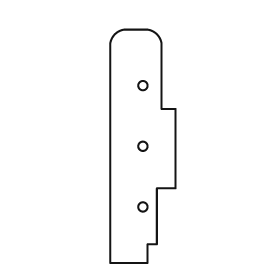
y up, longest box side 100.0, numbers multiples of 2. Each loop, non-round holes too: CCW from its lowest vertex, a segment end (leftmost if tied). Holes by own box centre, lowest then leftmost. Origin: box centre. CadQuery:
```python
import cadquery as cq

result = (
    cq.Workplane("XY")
    .moveTo(-14.0, -50.0)
    .lineTo(2.0, -50.0)
    .lineTo(2.0, -42.0)
    .lineTo(6.0, -42.0)
    .lineTo(6.0, -18.0)
    .lineTo(14.0, -18.0)
    .lineTo(14.0, 16.0)
    .lineTo(8.0, 16.0)
    .lineTo(8.0, 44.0)
    .threePointArc((6.0, 48.0), (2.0, 50.0))
    .lineTo(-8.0, 50.0)
    .threePointArc((-12.0, 48.0), (-14.0, 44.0))
    .close()
    .moveTo(0.0, -26.0)
    .circle(2.0)
    .moveTo(0.0, 0.0)
    .circle(2.0)
    .moveTo(0.0, 26.0)
    .circle(2.0)
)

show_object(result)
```